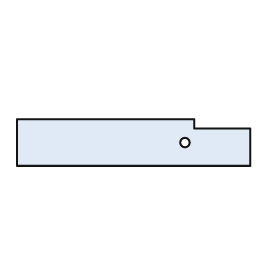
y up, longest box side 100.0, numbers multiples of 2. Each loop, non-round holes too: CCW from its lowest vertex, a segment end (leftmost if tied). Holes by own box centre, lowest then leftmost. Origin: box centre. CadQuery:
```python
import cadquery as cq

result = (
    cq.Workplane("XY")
    .moveTo(-50.0, -10.0)
    .lineTo(50.0, -10.0)
    .lineTo(50.0, 6.0)
    .lineTo(26.0, 6.0)
    .lineTo(26.0, 10.0)
    .lineTo(-50.0, 10.0)
    .close()
    .moveTo(22.0, 0.0)
    .circle(2.0)
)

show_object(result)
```